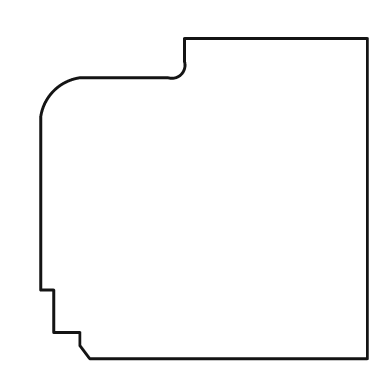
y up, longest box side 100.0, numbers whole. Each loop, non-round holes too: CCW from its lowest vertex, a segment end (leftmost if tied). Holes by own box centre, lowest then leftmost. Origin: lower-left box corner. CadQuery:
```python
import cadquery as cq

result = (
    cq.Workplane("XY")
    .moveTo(15.0, 0.0)
    .lineTo(100.0, 0.0)
    .lineTo(100.0, 98.0)
    .lineTo(44.0, 98.0)
    .lineTo(44.0, 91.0)
    .threePointArc((43.0, 87.0), (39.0, 86.0))
    .lineTo(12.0, 86.0)
    .threePointArc((4.0, 82.0), (0.0, 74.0))
    .lineTo(0.0, 21.0)
    .lineTo(4.0, 21.0)
    .lineTo(4.0, 8.0)
    .lineTo(12.0, 8.0)
    .lineTo(12.0, 4.0)
    .close()
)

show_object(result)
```